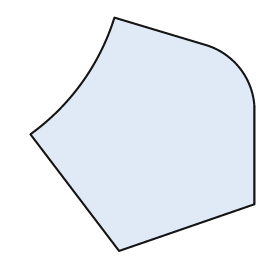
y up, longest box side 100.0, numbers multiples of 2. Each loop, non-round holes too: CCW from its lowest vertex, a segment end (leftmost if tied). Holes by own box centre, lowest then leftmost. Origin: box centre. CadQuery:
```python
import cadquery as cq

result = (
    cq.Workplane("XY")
    .moveTo(-10.0, -50.0)
    .lineTo(48.0, -30.0)
    .lineTo(48.0, 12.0)
    .threePointArc((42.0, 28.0), (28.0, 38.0))
    .lineTo(-12.0, 50.0)
    .threePointArc((-26.0, 22.0), (-48.0, 0.0))
    .close()
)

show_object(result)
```